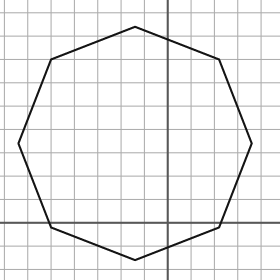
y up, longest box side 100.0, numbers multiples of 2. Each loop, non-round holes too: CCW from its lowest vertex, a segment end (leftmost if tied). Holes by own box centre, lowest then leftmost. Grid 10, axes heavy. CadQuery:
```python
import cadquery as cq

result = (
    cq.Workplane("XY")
    .moveTo(-14.0, -16.0)
    .lineTo(22.0, -2.0)
    .lineTo(36.0, 34.0)
    .lineTo(22.0, 70.0)
    .lineTo(-14.0, 84.0)
    .lineTo(-50.0, 70.0)
    .lineTo(-64.0, 34.0)
    .lineTo(-50.0, -2.0)
    .close()
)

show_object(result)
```